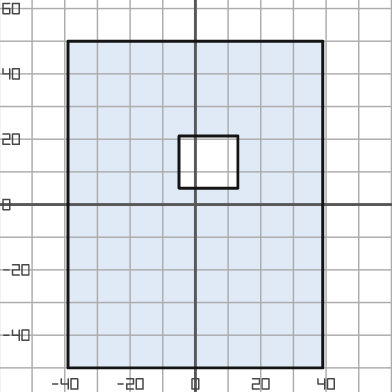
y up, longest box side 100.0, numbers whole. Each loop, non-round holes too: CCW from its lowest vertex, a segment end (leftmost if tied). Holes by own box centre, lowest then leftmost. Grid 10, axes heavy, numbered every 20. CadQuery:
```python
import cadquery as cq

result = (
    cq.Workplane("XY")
    .moveTo(-39.0, -50.0)
    .lineTo(39.0, -50.0)
    .lineTo(39.0, 50.0)
    .lineTo(-39.0, 50.0)
    .close()
    .moveTo(-5.0, 5.0)
    .lineTo(13.0, 5.0)
    .lineTo(13.0, 21.0)
    .lineTo(-5.0, 21.0)
    .close()
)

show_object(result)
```